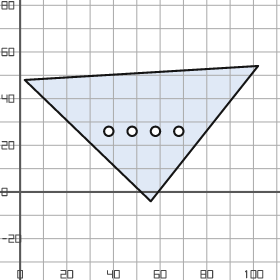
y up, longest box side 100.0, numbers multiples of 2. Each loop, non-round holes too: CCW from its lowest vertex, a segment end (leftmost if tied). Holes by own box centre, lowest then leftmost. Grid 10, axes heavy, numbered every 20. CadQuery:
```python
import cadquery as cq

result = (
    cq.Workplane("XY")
    .moveTo(56.0, -4.0)
    .lineTo(102.0, 54.0)
    .lineTo(2.0, 48.0)
    .close()
    .moveTo(38.0, 26.0)
    .circle(2.0)
    .moveTo(48.0, 26.0)
    .circle(2.0)
    .moveTo(58.0, 26.0)
    .circle(2.0)
    .moveTo(68.0, 26.0)
    .circle(2.0)
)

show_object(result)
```